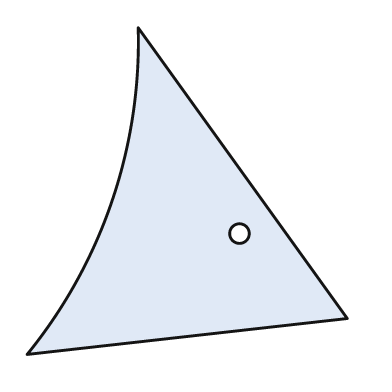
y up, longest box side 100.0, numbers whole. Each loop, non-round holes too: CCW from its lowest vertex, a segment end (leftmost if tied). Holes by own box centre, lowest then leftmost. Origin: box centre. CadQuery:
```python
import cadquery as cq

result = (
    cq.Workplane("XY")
    .moveTo(-49.0, -50.0)
    .lineTo(49.0, -39.0)
    .lineTo(-15.0, 50.0)
    .threePointArc((-23.0, -3.0), (-49.0, -50.0))
    .close()
    .moveTo(16.0, -13.0)
    .circle(3.0)
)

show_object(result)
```